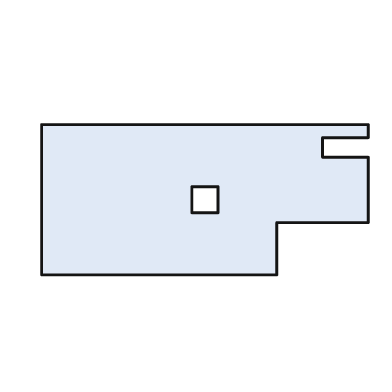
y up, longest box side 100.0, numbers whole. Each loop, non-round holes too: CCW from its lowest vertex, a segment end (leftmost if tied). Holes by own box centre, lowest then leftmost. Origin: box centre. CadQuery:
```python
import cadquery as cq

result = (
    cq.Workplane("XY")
    .moveTo(-50.0, -23.0)
    .lineTo(22.0, -23.0)
    .lineTo(22.0, -7.0)
    .lineTo(50.0, -7.0)
    .lineTo(50.0, 13.0)
    .lineTo(36.0, 13.0)
    .lineTo(36.0, 19.0)
    .lineTo(50.0, 19.0)
    .lineTo(50.0, 23.0)
    .lineTo(-50.0, 23.0)
    .close()
    .moveTo(-4.0, -4.0)
    .lineTo(4.0, -4.0)
    .lineTo(4.0, 4.0)
    .lineTo(-4.0, 4.0)
    .close()
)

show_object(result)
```